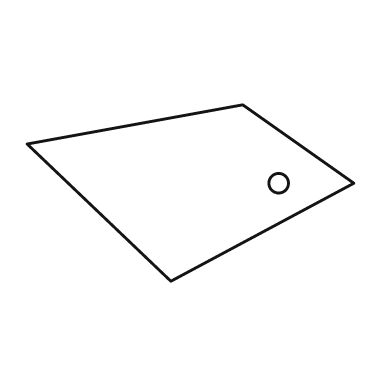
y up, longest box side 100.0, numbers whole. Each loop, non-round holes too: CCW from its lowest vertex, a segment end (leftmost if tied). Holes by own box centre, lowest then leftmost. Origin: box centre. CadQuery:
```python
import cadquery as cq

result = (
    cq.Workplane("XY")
    .moveTo(-6.0, -27.0)
    .lineTo(50.0, 3.0)
    .lineTo(16.0, 27.0)
    .lineTo(-50.0, 15.0)
    .close()
    .moveTo(27.0, 3.0)
    .circle(3.0)
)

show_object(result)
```